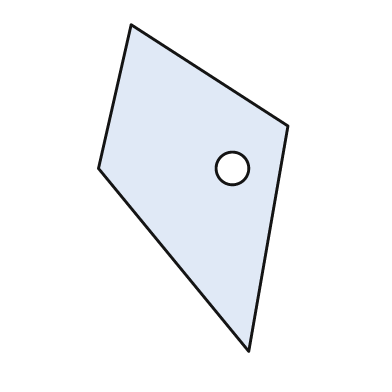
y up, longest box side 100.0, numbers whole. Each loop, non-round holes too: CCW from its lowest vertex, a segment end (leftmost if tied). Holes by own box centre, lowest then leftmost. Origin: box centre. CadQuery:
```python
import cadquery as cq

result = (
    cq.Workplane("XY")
    .moveTo(17.0, -50.0)
    .lineTo(29.0, 19.0)
    .lineTo(-19.0, 50.0)
    .lineTo(-29.0, 6.0)
    .close()
    .moveTo(12.0, 6.0)
    .circle(5.0)
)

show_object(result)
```